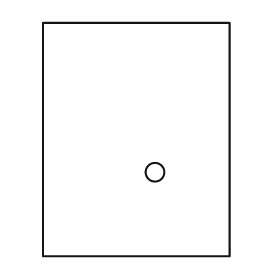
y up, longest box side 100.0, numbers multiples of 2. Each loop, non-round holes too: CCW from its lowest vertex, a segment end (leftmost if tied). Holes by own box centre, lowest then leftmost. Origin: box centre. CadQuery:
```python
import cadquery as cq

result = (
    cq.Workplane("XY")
    .moveTo(-40.0, -50.0)
    .lineTo(40.0, -50.0)
    .lineTo(40.0, 50.0)
    .lineTo(-40.0, 50.0)
    .close()
    .moveTo(8.0, -14.0)
    .circle(4.0)
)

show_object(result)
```